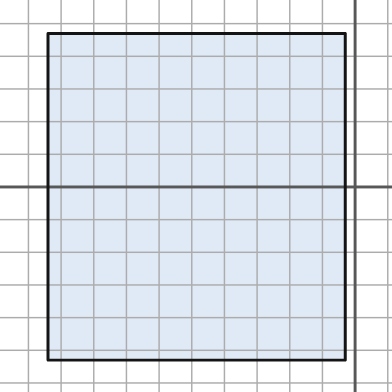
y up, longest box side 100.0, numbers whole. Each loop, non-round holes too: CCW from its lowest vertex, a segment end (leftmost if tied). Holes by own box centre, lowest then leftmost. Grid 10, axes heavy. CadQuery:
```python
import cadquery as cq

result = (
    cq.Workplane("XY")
    .moveTo(-94.0, -53.0)
    .lineTo(-3.0, -53.0)
    .lineTo(-3.0, 47.0)
    .lineTo(-94.0, 47.0)
    .close()
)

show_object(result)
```